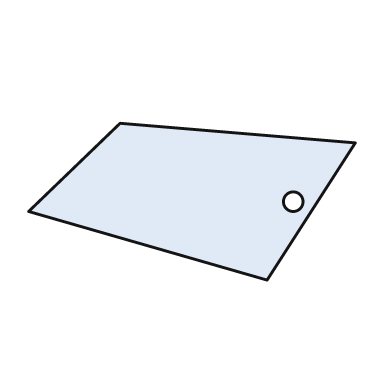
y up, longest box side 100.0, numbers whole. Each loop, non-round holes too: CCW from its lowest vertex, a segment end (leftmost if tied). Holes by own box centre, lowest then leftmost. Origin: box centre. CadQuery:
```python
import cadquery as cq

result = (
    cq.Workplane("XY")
    .moveTo(23.0, -24.0)
    .lineTo(50.0, 18.0)
    .lineTo(-22.0, 24.0)
    .lineTo(-50.0, -3.0)
    .close()
    .moveTo(31.0, 0.0)
    .circle(3.0)
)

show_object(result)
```